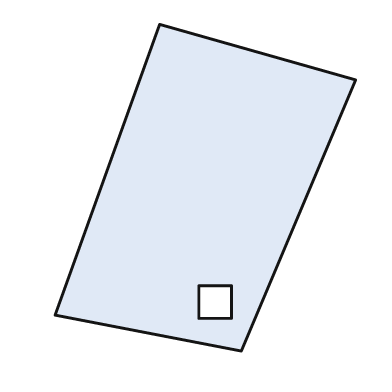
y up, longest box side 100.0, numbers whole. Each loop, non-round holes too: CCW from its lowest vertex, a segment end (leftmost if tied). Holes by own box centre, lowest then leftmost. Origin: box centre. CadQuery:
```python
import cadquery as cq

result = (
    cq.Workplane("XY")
    .moveTo(11.0, -50.0)
    .lineTo(46.0, 33.0)
    .lineTo(-14.0, 50.0)
    .lineTo(-46.0, -39.0)
    .close()
    .moveTo(-2.0, -40.0)
    .lineTo(8.0, -40.0)
    .lineTo(8.0, -30.0)
    .lineTo(-2.0, -30.0)
    .close()
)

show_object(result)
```